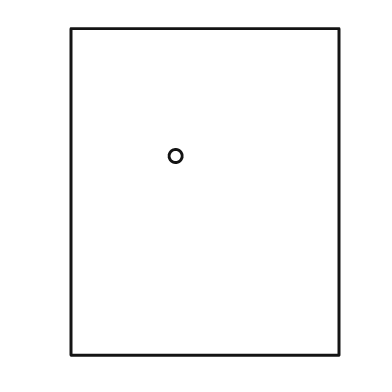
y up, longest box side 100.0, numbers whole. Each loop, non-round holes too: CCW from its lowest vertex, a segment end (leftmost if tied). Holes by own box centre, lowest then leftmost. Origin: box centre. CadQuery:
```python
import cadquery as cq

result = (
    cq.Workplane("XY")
    .moveTo(-41.0, -50.0)
    .lineTo(41.0, -50.0)
    .lineTo(41.0, 50.0)
    .lineTo(-41.0, 50.0)
    .close()
    .moveTo(-9.0, 11.0)
    .circle(2.0)
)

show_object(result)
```